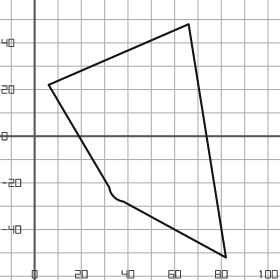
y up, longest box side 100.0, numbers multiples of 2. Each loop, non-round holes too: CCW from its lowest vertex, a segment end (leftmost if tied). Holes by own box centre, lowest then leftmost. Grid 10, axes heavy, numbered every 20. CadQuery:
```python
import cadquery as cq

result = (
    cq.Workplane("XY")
    .moveTo(82.0, -52.0)
    .lineTo(66.0, 48.0)
    .lineTo(6.0, 22.0)
    .lineTo(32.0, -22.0)
    .threePointArc((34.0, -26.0), (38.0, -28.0))
    .close()
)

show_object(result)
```